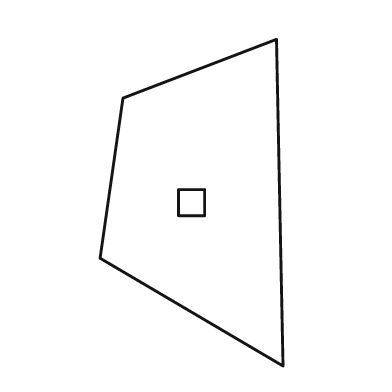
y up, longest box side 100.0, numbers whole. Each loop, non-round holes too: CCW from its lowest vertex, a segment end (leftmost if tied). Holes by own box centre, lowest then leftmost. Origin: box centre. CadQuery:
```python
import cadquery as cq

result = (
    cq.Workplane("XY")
    .moveTo(28.0, -50.0)
    .lineTo(26.0, 50.0)
    .lineTo(-21.0, 32.0)
    .lineTo(-28.0, -17.0)
    .close()
    .moveTo(-4.0, -4.0)
    .lineTo(4.0, -4.0)
    .lineTo(4.0, 4.0)
    .lineTo(-4.0, 4.0)
    .close()
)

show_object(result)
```